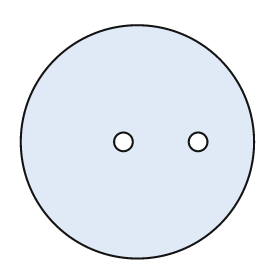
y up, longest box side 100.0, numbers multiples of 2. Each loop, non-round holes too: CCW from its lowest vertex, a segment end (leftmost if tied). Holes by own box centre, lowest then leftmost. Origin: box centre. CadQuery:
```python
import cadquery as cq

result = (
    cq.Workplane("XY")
    .moveTo(0.0, 0.0)
    .circle(50.0)
    .moveTo(-6.0, 0.0)
    .circle(4.0)
    .moveTo(26.0, 0.0)
    .circle(4.0)
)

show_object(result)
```